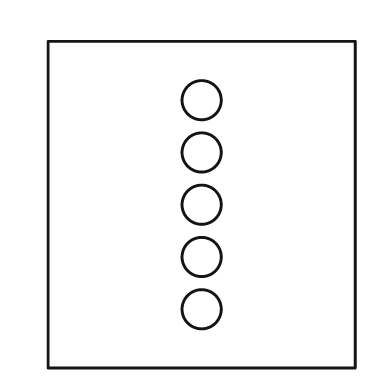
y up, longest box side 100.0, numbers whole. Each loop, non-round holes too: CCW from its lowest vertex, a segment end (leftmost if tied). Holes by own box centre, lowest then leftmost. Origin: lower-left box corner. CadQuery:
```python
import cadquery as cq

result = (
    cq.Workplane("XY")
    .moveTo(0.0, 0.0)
    .lineTo(94.0, 0.0)
    .lineTo(94.0, 100.0)
    .lineTo(0.0, 100.0)
    .close()
    .moveTo(47.0, 18.0)
    .circle(6.0)
    .moveTo(47.0, 34.0)
    .circle(6.0)
    .moveTo(47.0, 50.0)
    .circle(6.0)
    .moveTo(47.0, 66.0)
    .circle(6.0)
    .moveTo(47.0, 82.0)
    .circle(6.0)
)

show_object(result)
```